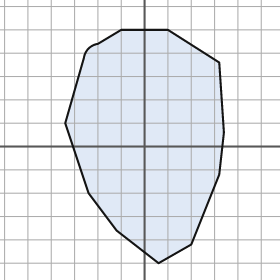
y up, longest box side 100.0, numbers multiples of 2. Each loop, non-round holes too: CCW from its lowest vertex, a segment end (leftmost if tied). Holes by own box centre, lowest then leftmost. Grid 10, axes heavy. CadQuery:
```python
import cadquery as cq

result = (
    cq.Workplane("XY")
    .moveTo(6.0, -50.0)
    .lineTo(20.0, -42.0)
    .lineTo(32.0, -12.0)
    .lineTo(34.0, 6.0)
    .lineTo(32.0, 36.0)
    .lineTo(10.0, 50.0)
    .lineTo(-10.0, 50.0)
    .lineTo(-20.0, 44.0)
    .threePointArc((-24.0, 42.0), (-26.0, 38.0))
    .lineTo(-34.0, 10.0)
    .lineTo(-24.0, -20.0)
    .lineTo(-12.0, -36.0)
    .close()
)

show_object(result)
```